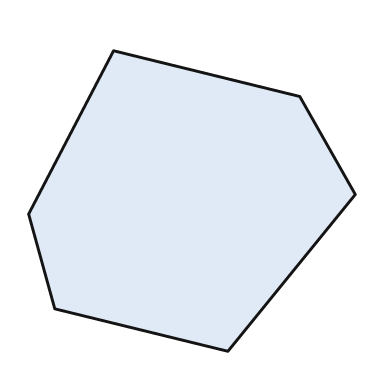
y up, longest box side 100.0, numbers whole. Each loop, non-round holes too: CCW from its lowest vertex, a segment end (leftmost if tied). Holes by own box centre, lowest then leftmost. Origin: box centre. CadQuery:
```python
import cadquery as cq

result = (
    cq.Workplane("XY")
    .moveTo(11.0, -46.0)
    .lineTo(50.0, 2.0)
    .lineTo(33.0, 32.0)
    .lineTo(-24.0, 46.0)
    .lineTo(-50.0, -4.0)
    .lineTo(-42.0, -33.0)
    .close()
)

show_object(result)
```